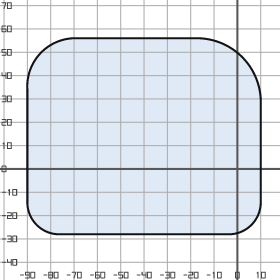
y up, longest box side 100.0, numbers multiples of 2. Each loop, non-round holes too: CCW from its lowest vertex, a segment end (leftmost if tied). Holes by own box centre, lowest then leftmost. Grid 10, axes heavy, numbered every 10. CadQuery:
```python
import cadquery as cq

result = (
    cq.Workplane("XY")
    .moveTo(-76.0, -28.0)
    .lineTo(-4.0, -28.0)
    .threePointArc((6.0, -24.0), (10.0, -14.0))
    .lineTo(10.0, 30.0)
    .threePointArc((2.0, 48.0), (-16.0, 56.0))
    .lineTo(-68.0, 56.0)
    .threePointArc((-84.0, 50.0), (-90.0, 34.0))
    .lineTo(-90.0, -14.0)
    .threePointArc((-86.0, -24.0), (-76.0, -28.0))
    .close()
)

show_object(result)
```